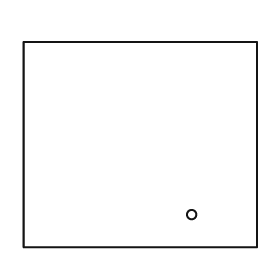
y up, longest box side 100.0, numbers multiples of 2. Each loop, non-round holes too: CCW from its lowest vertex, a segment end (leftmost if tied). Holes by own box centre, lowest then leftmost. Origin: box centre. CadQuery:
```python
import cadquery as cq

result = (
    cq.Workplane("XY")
    .moveTo(-50.0, -44.0)
    .lineTo(50.0, -44.0)
    .lineTo(50.0, 44.0)
    .lineTo(-50.0, 44.0)
    .close()
    .moveTo(22.0, -30.0)
    .circle(2.0)
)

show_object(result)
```